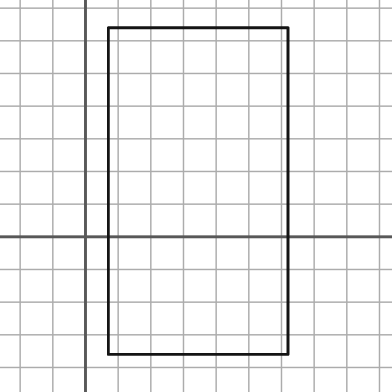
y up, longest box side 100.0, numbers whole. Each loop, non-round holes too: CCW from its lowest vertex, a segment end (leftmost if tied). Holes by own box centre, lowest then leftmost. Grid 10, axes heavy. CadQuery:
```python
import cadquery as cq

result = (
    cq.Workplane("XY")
    .moveTo(7.0, -36.0)
    .lineTo(62.0, -36.0)
    .lineTo(62.0, 64.0)
    .lineTo(7.0, 64.0)
    .close()
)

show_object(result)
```